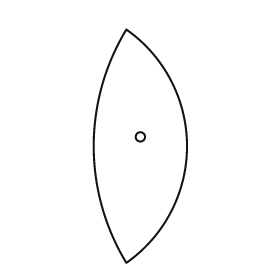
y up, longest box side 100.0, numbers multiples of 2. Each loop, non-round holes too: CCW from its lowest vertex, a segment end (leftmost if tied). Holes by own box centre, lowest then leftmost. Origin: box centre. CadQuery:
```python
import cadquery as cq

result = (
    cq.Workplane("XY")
    .moveTo(-6.0, -50.0)
    .threePointArc((20.0, 0.0), (-6.0, 50.0))
    .threePointArc((-20.0, 0.0), (-6.0, -50.0))
    .close()
    .moveTo(0.0, 4.0)
    .circle(2.0)
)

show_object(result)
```